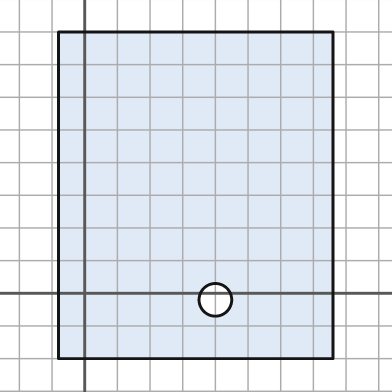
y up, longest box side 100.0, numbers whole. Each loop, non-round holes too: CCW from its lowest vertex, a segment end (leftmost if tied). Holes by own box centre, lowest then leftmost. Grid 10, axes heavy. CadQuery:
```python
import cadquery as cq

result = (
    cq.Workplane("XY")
    .moveTo(-8.0, -20.0)
    .lineTo(76.0, -20.0)
    .lineTo(76.0, 80.0)
    .lineTo(-8.0, 80.0)
    .close()
    .moveTo(40.0, -2.0)
    .circle(5.0)
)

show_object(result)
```